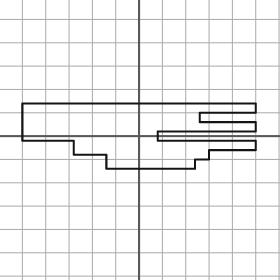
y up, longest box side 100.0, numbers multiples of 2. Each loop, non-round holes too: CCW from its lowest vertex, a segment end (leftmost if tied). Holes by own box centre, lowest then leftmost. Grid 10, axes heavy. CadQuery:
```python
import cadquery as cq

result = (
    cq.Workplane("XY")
    .moveTo(-14.0, -14.0)
    .lineTo(24.0, -14.0)
    .lineTo(24.0, -10.0)
    .lineTo(30.0, -10.0)
    .lineTo(30.0, -6.0)
    .lineTo(50.0, -6.0)
    .lineTo(50.0, -2.0)
    .lineTo(8.0, -2.0)
    .lineTo(8.0, 2.0)
    .lineTo(50.0, 2.0)
    .lineTo(50.0, 6.0)
    .lineTo(26.0, 6.0)
    .lineTo(26.0, 10.0)
    .lineTo(50.0, 10.0)
    .lineTo(50.0, 14.0)
    .lineTo(-50.0, 14.0)
    .lineTo(-50.0, -2.0)
    .lineTo(-28.0, -2.0)
    .lineTo(-28.0, -8.0)
    .lineTo(-14.0, -8.0)
    .close()
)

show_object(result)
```